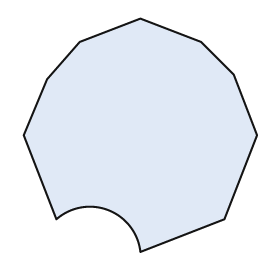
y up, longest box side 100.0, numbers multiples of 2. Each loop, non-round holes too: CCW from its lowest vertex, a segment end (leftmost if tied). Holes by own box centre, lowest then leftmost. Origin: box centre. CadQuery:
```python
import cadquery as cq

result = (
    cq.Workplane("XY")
    .moveTo(0.0, -50.0)
    .lineTo(36.0, -36.0)
    .lineTo(50.0, 0.0)
    .lineTo(40.0, 26.0)
    .lineTo(26.0, 40.0)
    .lineTo(0.0, 50.0)
    .lineTo(-26.0, 40.0)
    .lineTo(-40.0, 24.0)
    .lineTo(-50.0, 0.0)
    .lineTo(-36.0, -36.0)
    .threePointArc((-14.0, -32.0), (0.0, -50.0))
    .close()
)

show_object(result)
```